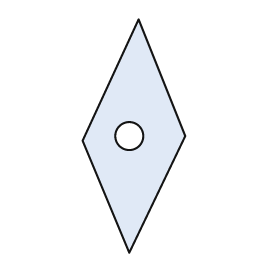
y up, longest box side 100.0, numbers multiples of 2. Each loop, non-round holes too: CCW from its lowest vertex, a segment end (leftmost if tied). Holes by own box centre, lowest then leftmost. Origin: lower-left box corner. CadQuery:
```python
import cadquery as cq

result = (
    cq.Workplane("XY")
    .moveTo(20.0, 0.0)
    .lineTo(44.0, 50.0)
    .lineTo(24.0, 100.0)
    .lineTo(0.0, 48.0)
    .close()
    .moveTo(20.0, 50.0)
    .circle(6.0)
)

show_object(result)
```